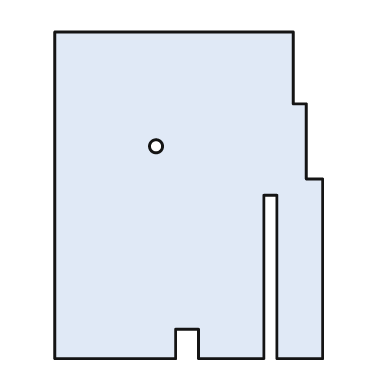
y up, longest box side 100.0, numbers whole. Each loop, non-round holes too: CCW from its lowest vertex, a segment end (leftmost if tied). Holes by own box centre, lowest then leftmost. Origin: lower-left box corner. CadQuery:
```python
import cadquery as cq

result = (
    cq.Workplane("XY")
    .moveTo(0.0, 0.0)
    .lineTo(37.0, 0.0)
    .lineTo(37.0, 9.0)
    .lineTo(44.0, 9.0)
    .lineTo(44.0, 0.0)
    .lineTo(64.0, 0.0)
    .lineTo(64.0, 50.0)
    .lineTo(68.0, 50.0)
    .lineTo(68.0, 0.0)
    .lineTo(82.0, 0.0)
    .lineTo(82.0, 55.0)
    .lineTo(77.0, 55.0)
    .lineTo(77.0, 78.0)
    .lineTo(73.0, 78.0)
    .lineTo(73.0, 100.0)
    .lineTo(0.0, 100.0)
    .close()
    .moveTo(31.0, 65.0)
    .circle(2.0)
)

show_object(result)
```